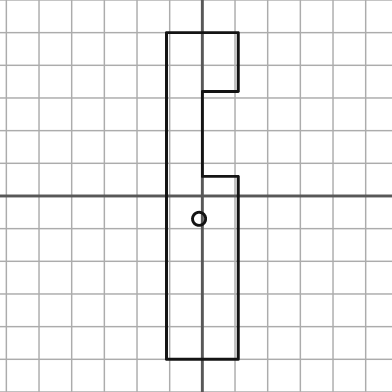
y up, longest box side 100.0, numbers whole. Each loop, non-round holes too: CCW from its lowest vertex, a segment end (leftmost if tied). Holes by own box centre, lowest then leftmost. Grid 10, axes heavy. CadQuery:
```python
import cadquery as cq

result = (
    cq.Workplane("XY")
    .moveTo(-11.0, -50.0)
    .lineTo(11.0, -50.0)
    .lineTo(11.0, 6.0)
    .lineTo(0.0, 6.0)
    .lineTo(0.0, 32.0)
    .lineTo(11.0, 32.0)
    .lineTo(11.0, 50.0)
    .lineTo(-11.0, 50.0)
    .close()
    .moveTo(-1.0, -7.0)
    .circle(2.0)
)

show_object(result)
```